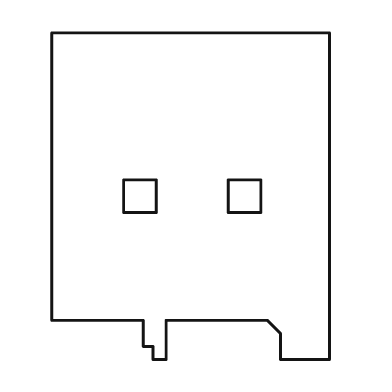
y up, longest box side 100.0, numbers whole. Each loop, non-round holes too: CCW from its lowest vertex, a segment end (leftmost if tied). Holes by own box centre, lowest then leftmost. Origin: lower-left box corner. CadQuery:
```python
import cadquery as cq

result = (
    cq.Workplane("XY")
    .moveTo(31.0, 0.0)
    .lineTo(35.0, 0.0)
    .lineTo(35.0, 12.0)
    .lineTo(66.0, 12.0)
    .lineTo(70.0, 8.0)
    .lineTo(70.0, 0.0)
    .lineTo(85.0, 0.0)
    .lineTo(85.0, 100.0)
    .lineTo(0.0, 100.0)
    .lineTo(0.0, 12.0)
    .lineTo(28.0, 12.0)
    .lineTo(28.0, 4.0)
    .lineTo(31.0, 4.0)
    .close()
    .moveTo(22.0, 45.0)
    .lineTo(32.0, 45.0)
    .lineTo(32.0, 55.0)
    .lineTo(22.0, 55.0)
    .close()
    .moveTo(54.0, 45.0)
    .lineTo(64.0, 45.0)
    .lineTo(64.0, 55.0)
    .lineTo(54.0, 55.0)
    .close()
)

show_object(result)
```